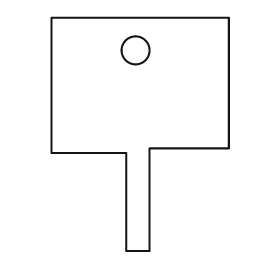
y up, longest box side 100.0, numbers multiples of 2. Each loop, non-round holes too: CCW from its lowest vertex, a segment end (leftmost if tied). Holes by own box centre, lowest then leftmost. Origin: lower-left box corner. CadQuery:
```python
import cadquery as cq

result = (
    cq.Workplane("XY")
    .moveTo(32.0, 0.0)
    .lineTo(42.0, 0.0)
    .lineTo(42.0, 44.0)
    .lineTo(76.0, 44.0)
    .lineTo(76.0, 100.0)
    .lineTo(0.0, 100.0)
    .lineTo(0.0, 42.0)
    .lineTo(32.0, 42.0)
    .close()
    .moveTo(36.0, 86.0)
    .circle(6.0)
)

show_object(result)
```